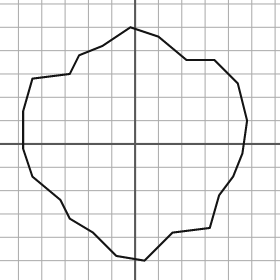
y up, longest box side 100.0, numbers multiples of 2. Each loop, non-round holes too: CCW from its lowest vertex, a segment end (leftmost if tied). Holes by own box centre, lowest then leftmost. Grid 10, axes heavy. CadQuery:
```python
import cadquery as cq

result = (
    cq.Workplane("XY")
    .moveTo(4.0, -50.0)
    .lineTo(16.0, -38.0)
    .lineTo(32.0, -36.0)
    .lineTo(36.0, -22.0)
    .lineTo(42.0, -14.0)
    .lineTo(46.0, -4.0)
    .lineTo(48.0, 10.0)
    .lineTo(44.0, 26.0)
    .lineTo(34.0, 36.0)
    .lineTo(22.0, 36.0)
    .lineTo(10.0, 46.0)
    .lineTo(-2.0, 50.0)
    .lineTo(-14.0, 42.0)
    .lineTo(-24.0, 38.0)
    .lineTo(-28.0, 30.0)
    .lineTo(-44.0, 28.0)
    .lineTo(-48.0, 14.0)
    .lineTo(-48.0, -2.0)
    .lineTo(-44.0, -14.0)
    .lineTo(-32.0, -24.0)
    .lineTo(-28.0, -32.0)
    .lineTo(-18.0, -38.0)
    .lineTo(-8.0, -48.0)
    .close()
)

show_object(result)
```